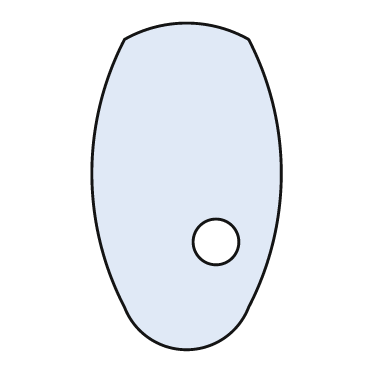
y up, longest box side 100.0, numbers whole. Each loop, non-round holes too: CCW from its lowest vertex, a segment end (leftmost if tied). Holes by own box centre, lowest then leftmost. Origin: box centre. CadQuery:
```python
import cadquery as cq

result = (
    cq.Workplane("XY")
    .moveTo(-19.0, -37.0)
    .threePointArc((0.0, -50.0), (19.0, -37.0))
    .threePointArc((29.0, 4.0), (19.0, 45.0))
    .threePointArc((0.0, 50.0), (-19.0, 45.0))
    .threePointArc((-29.0, 4.0), (-19.0, -37.0))
    .close()
    .moveTo(9.0, -17.0)
    .circle(7.0)
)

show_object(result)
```